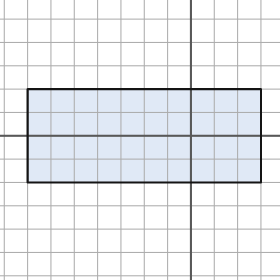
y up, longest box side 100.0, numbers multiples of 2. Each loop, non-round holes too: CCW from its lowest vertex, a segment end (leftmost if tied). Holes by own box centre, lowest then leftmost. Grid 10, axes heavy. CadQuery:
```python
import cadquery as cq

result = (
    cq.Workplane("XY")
    .moveTo(-70.0, -20.0)
    .lineTo(30.0, -20.0)
    .lineTo(30.0, 20.0)
    .lineTo(-70.0, 20.0)
    .close()
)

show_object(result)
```